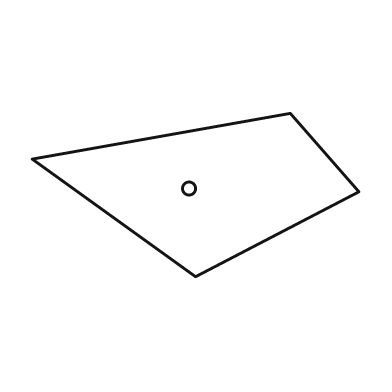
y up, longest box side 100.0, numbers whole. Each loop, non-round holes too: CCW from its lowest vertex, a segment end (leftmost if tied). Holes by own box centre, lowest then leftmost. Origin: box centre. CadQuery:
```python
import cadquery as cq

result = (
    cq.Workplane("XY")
    .moveTo(0.0, -25.0)
    .lineTo(50.0, 1.0)
    .lineTo(29.0, 25.0)
    .lineTo(-50.0, 11.0)
    .close()
    .moveTo(-2.0, 2.0)
    .circle(2.0)
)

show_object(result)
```